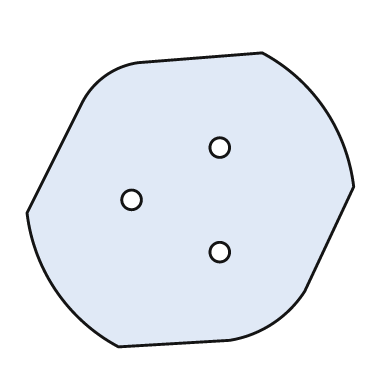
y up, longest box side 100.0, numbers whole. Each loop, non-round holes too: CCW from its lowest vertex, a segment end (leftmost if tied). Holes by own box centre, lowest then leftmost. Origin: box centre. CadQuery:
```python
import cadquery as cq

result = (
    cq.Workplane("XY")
    .moveTo(-22.0, -45.0)
    .lineTo(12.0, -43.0)
    .threePointArc((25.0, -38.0), (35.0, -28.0))
    .lineTo(50.0, 4.0)
    .threePointArc((41.0, 28.0), (22.0, 45.0))
    .lineTo(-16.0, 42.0)
    .threePointArc((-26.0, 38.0), (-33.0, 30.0))
    .lineTo(-50.0, -4.0)
    .threePointArc((-41.0, -28.0), (-22.0, -45.0))
    .close()
    .moveTo(9.0, -16.0)
    .circle(3.0)
    .moveTo(-18.0, 0.0)
    .circle(3.0)
    .moveTo(9.0, 16.0)
    .circle(3.0)
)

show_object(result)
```